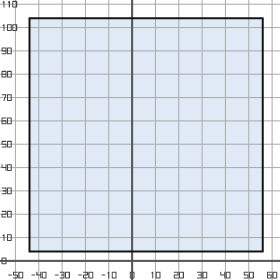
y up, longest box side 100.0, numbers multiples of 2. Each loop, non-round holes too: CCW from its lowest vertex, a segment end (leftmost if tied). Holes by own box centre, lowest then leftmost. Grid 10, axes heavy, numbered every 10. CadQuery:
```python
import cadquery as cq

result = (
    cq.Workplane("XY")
    .moveTo(-44.0, 4.0)
    .lineTo(56.0, 4.0)
    .lineTo(56.0, 104.0)
    .lineTo(-44.0, 104.0)
    .close()
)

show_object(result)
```